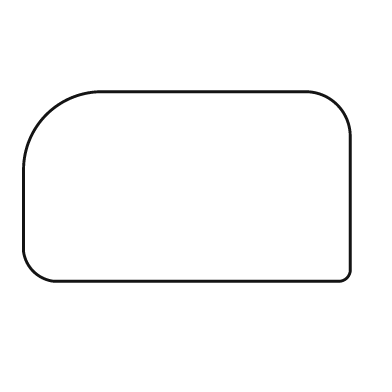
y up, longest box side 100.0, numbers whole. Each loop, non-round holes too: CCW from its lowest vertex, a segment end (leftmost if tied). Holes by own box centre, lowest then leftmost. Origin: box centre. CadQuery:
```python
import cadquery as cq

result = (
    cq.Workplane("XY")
    .moveTo(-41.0, -29.0)
    .lineTo(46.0, -29.0)
    .threePointArc((49.0, -28.0), (50.0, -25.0))
    .lineTo(50.0, 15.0)
    .threePointArc((46.0, 25.0), (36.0, 29.0))
    .lineTo(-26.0, 29.0)
    .threePointArc((-43.0, 22.0), (-50.0, 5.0))
    .lineTo(-50.0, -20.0)
    .threePointArc((-47.0, -26.0), (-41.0, -29.0))
    .close()
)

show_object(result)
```